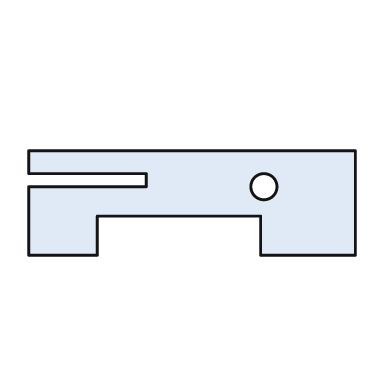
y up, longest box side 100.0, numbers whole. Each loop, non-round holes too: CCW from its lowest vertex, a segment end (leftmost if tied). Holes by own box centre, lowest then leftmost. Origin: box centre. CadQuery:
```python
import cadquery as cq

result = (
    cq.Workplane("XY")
    .moveTo(-50.0, -16.0)
    .lineTo(-29.0, -16.0)
    .lineTo(-29.0, -4.0)
    .lineTo(21.0, -4.0)
    .lineTo(21.0, -16.0)
    .lineTo(50.0, -16.0)
    .lineTo(50.0, 16.0)
    .lineTo(-50.0, 16.0)
    .lineTo(-50.0, 9.0)
    .lineTo(-14.0, 9.0)
    .lineTo(-14.0, 5.0)
    .lineTo(-50.0, 5.0)
    .close()
    .moveTo(22.0, 5.0)
    .circle(4.0)
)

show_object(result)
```